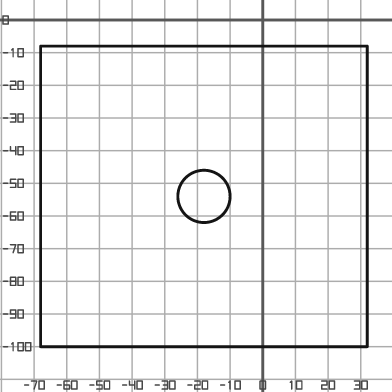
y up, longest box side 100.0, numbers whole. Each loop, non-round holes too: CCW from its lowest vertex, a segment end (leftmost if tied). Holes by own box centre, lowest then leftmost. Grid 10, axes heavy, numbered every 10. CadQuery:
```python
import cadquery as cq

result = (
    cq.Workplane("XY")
    .moveTo(-68.0, -100.0)
    .lineTo(32.0, -100.0)
    .lineTo(32.0, -8.0)
    .lineTo(-68.0, -8.0)
    .close()
    .moveTo(-18.0, -54.0)
    .circle(8.0)
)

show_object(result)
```